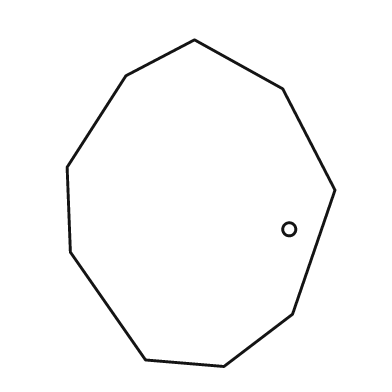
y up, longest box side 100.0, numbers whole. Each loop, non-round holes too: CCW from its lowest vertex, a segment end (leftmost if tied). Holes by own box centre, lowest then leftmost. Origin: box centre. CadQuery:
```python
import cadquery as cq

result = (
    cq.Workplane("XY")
    .moveTo(7.0, -50.0)
    .lineTo(28.0, -34.0)
    .lineTo(41.0, 4.0)
    .lineTo(25.0, 35.0)
    .lineTo(-2.0, 50.0)
    .lineTo(-23.0, 39.0)
    .lineTo(-41.0, 11.0)
    .lineTo(-40.0, -15.0)
    .lineTo(-17.0, -48.0)
    .close()
    .moveTo(27.0, -8.0)
    .circle(2.0)
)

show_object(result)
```